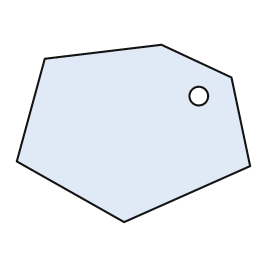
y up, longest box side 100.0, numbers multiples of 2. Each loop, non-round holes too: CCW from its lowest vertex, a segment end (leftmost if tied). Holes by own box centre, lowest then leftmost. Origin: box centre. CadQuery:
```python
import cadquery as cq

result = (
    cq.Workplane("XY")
    .moveTo(-4.0, -38.0)
    .lineTo(50.0, -14.0)
    .lineTo(42.0, 24.0)
    .lineTo(12.0, 38.0)
    .lineTo(-38.0, 32.0)
    .lineTo(-50.0, -12.0)
    .close()
    .moveTo(28.0, 16.0)
    .circle(4.0)
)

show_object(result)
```